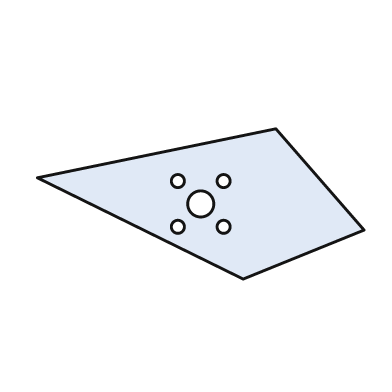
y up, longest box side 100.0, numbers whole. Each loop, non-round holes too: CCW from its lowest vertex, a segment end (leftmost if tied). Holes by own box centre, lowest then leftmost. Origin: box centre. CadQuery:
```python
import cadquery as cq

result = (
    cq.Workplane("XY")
    .moveTo(13.0, -23.0)
    .lineTo(50.0, -8.0)
    .lineTo(23.0, 23.0)
    .lineTo(-50.0, 8.0)
    .close()
    .moveTo(-7.0, -7.0)
    .circle(2.0)
    .moveTo(7.0, -7.0)
    .circle(2.0)
    .moveTo(0.0, 0.0)
    .circle(4.0)
    .moveTo(-7.0, 7.0)
    .circle(2.0)
    .moveTo(7.0, 7.0)
    .circle(2.0)
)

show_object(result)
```